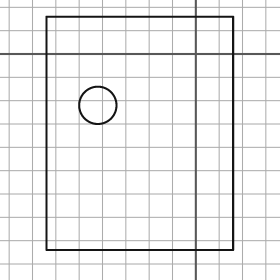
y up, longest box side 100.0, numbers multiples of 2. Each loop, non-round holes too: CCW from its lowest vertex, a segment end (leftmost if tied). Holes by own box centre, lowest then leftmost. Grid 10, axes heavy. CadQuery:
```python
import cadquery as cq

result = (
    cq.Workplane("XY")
    .moveTo(-64.0, -84.0)
    .lineTo(16.0, -84.0)
    .lineTo(16.0, 16.0)
    .lineTo(-64.0, 16.0)
    .close()
    .moveTo(-42.0, -22.0)
    .circle(8.0)
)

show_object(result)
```